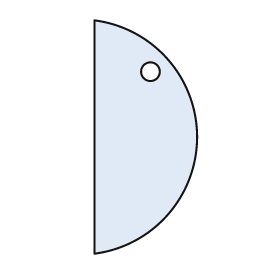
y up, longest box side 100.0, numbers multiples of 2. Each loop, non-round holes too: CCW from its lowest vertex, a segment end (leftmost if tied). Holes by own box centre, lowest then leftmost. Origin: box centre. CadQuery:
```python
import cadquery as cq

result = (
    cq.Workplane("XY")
    .moveTo(-22.0, -50.0)
    .threePointArc((22.0, 0.0), (-22.0, 50.0))
    .close()
    .moveTo(2.0, 28.0)
    .circle(4.0)
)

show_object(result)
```